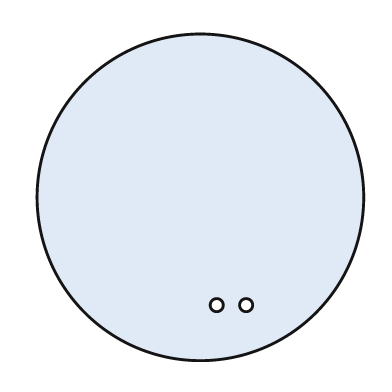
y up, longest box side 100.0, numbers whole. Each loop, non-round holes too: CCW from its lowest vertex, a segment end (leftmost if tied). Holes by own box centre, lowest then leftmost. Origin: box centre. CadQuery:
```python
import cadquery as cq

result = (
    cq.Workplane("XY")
    .moveTo(0.0, 0.0)
    .circle(50.0)
    .moveTo(5.0, -33.0)
    .circle(2.0)
    .moveTo(14.0, -33.0)
    .circle(2.0)
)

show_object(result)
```